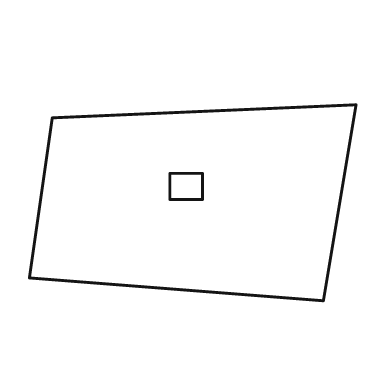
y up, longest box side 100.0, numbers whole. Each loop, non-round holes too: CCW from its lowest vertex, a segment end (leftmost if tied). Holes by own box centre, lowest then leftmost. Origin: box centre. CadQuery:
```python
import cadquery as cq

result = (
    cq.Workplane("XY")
    .moveTo(40.0, -30.0)
    .lineTo(50.0, 30.0)
    .lineTo(-43.0, 26.0)
    .lineTo(-50.0, -23.0)
    .close()
    .moveTo(-7.0, 1.0)
    .lineTo(3.0, 1.0)
    .lineTo(3.0, 9.0)
    .lineTo(-7.0, 9.0)
    .close()
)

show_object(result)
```